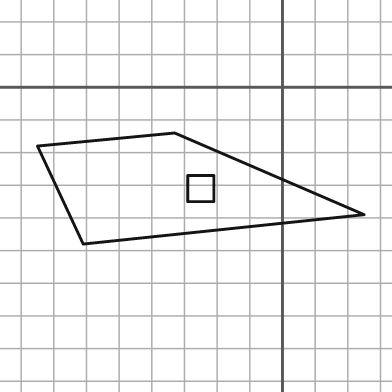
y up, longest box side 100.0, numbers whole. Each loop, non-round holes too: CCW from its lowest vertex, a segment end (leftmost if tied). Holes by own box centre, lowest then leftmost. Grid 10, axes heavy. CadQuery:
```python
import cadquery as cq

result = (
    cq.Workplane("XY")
    .moveTo(-61.0, -48.0)
    .lineTo(25.0, -39.0)
    .lineTo(-33.0, -14.0)
    .lineTo(-75.0, -18.0)
    .close()
    .moveTo(-29.0, -35.0)
    .lineTo(-21.0, -35.0)
    .lineTo(-21.0, -27.0)
    .lineTo(-29.0, -27.0)
    .close()
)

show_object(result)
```